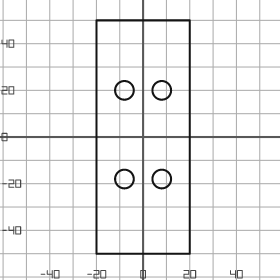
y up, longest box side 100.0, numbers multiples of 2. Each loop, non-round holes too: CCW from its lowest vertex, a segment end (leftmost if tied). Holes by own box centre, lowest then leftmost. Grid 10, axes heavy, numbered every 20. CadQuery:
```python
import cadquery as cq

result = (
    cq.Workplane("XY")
    .moveTo(-20.0, -50.0)
    .lineTo(20.0, -50.0)
    .lineTo(20.0, 50.0)
    .lineTo(-20.0, 50.0)
    .close()
    .moveTo(-8.0, -18.0)
    .circle(4.0)
    .moveTo(8.0, -18.0)
    .circle(4.0)
    .moveTo(-8.0, 20.0)
    .circle(4.0)
    .moveTo(8.0, 20.0)
    .circle(4.0)
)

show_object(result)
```